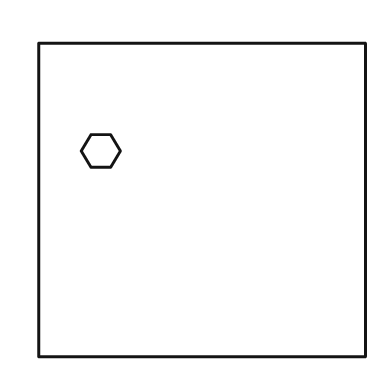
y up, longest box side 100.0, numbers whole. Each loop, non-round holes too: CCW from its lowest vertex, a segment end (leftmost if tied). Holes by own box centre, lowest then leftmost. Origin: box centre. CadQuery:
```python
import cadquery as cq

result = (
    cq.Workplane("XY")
    .moveTo(-50.0, -48.0)
    .lineTo(50.0, -48.0)
    .lineTo(50.0, 48.0)
    .lineTo(-50.0, 48.0)
    .close()
    .moveTo(-34.0, 10.0)
    .lineTo(-28.0, 10.0)
    .lineTo(-25.0, 15.0)
    .lineTo(-28.0, 20.0)
    .lineTo(-34.0, 20.0)
    .lineTo(-37.0, 15.0)
    .close()
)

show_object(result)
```